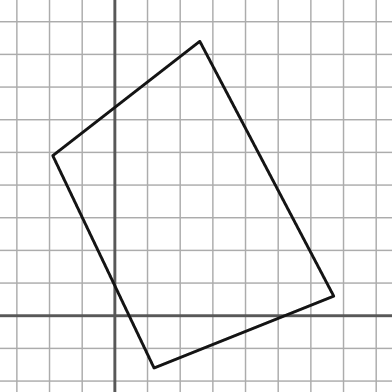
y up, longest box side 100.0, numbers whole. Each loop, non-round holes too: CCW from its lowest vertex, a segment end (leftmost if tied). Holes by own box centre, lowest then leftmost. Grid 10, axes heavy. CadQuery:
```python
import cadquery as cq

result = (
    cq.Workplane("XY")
    .moveTo(12.0, -16.0)
    .lineTo(67.0, 6.0)
    .lineTo(26.0, 84.0)
    .lineTo(-19.0, 49.0)
    .close()
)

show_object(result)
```